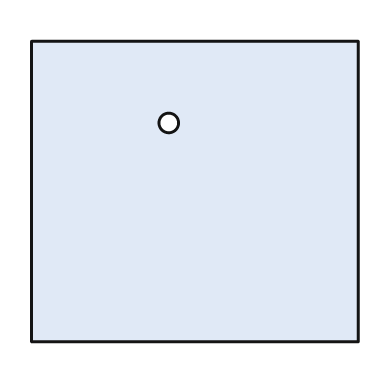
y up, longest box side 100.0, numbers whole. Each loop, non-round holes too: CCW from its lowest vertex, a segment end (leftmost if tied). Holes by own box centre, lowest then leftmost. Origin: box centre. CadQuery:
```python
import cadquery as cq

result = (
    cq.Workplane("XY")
    .moveTo(-50.0, -46.0)
    .lineTo(50.0, -46.0)
    .lineTo(50.0, 46.0)
    .lineTo(-50.0, 46.0)
    .close()
    .moveTo(-8.0, 21.0)
    .circle(3.0)
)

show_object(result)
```